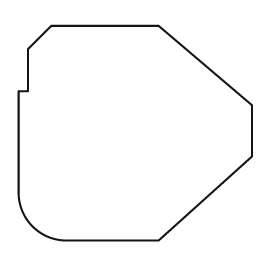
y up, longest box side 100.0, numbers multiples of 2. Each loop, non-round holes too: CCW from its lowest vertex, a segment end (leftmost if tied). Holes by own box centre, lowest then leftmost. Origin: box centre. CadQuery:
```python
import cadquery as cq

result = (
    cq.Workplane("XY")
    .moveTo(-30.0, -46.0)
    .lineTo(10.0, -46.0)
    .lineTo(50.0, -10.0)
    .lineTo(50.0, 12.0)
    .lineTo(10.0, 46.0)
    .lineTo(-36.0, 46.0)
    .lineTo(-46.0, 36.0)
    .lineTo(-46.0, 18.0)
    .lineTo(-50.0, 18.0)
    .lineTo(-50.0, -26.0)
    .threePointArc((-44.0, -40.0), (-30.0, -46.0))
    .close()
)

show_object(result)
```